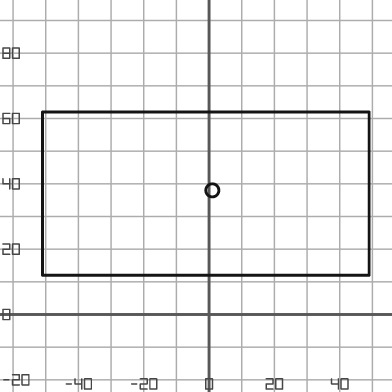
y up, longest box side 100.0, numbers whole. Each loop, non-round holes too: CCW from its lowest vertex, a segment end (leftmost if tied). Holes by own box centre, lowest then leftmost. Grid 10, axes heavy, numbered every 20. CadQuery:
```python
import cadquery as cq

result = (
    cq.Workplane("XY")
    .moveTo(-51.0, 12.0)
    .lineTo(49.0, 12.0)
    .lineTo(49.0, 62.0)
    .lineTo(-51.0, 62.0)
    .close()
    .moveTo(1.0, 38.0)
    .circle(2.0)
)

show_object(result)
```